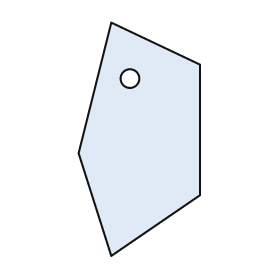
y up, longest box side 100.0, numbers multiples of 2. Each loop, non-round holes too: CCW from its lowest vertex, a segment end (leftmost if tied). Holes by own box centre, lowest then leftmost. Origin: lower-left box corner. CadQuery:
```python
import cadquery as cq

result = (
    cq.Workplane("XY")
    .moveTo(14.0, 0.0)
    .lineTo(52.0, 26.0)
    .lineTo(52.0, 82.0)
    .lineTo(14.0, 100.0)
    .lineTo(0.0, 44.0)
    .close()
    .moveTo(22.0, 76.0)
    .circle(4.0)
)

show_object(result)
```